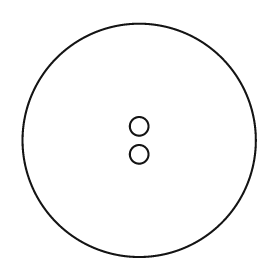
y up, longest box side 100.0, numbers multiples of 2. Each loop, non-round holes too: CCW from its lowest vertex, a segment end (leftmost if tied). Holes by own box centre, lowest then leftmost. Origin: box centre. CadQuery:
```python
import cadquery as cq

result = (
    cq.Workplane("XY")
    .moveTo(0.0, 0.0)
    .circle(50.0)
    .moveTo(0.0, -6.0)
    .circle(4.0)
    .moveTo(0.0, 6.0)
    .circle(4.0)
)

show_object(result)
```